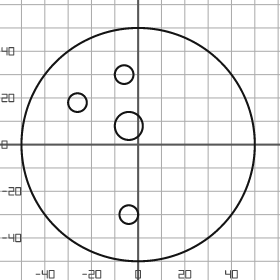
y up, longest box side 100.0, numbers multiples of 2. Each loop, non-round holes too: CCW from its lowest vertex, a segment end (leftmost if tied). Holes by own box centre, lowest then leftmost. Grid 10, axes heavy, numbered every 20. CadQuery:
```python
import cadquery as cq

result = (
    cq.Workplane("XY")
    .moveTo(0.0, 0.0)
    .circle(50.0)
    .moveTo(-4.0, -30.0)
    .circle(4.0)
    .moveTo(-4.0, 8.0)
    .circle(6.0)
    .moveTo(-26.0, 18.0)
    .circle(4.0)
    .moveTo(-6.0, 30.0)
    .circle(4.0)
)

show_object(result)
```